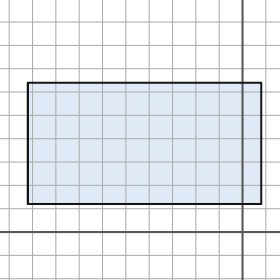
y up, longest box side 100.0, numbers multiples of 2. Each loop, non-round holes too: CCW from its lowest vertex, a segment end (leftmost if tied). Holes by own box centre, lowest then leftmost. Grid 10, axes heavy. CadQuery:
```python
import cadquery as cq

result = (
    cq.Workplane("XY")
    .moveTo(-92.0, 12.0)
    .lineTo(8.0, 12.0)
    .lineTo(8.0, 64.0)
    .lineTo(-92.0, 64.0)
    .close()
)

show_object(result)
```